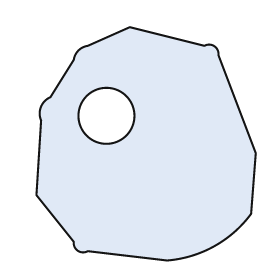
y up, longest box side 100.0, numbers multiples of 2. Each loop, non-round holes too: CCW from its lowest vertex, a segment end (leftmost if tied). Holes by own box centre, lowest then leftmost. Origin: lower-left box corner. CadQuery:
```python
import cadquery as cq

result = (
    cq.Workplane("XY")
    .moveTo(56.0, 0.0)
    .threePointArc((76.0, 6.0), (92.0, 20.0))
    .lineTo(94.0, 46.0)
    .lineTo(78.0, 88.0)
    .threePointArc((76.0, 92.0), (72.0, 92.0))
    .lineTo(40.0, 100.0)
    .lineTo(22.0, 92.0)
    .threePointArc((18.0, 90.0), (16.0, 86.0))
    .lineTo(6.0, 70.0)
    .threePointArc((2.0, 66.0), (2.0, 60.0))
    .lineTo(0.0, 28.0)
    .lineTo(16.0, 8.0)
    .threePointArc((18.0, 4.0), (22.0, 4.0))
    .close()
    .moveTo(30.0, 62.0)
    .circle(12.0)
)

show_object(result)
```